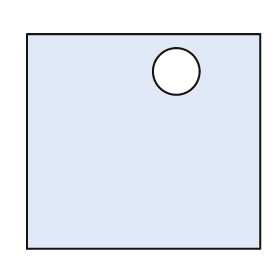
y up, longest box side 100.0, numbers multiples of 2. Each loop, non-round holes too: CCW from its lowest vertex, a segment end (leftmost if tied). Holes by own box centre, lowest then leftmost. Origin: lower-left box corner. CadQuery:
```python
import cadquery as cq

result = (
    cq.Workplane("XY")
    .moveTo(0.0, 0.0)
    .lineTo(100.0, 0.0)
    .lineTo(100.0, 92.0)
    .lineTo(0.0, 92.0)
    .close()
    .moveTo(64.0, 76.0)
    .circle(10.0)
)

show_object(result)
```